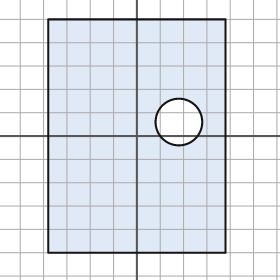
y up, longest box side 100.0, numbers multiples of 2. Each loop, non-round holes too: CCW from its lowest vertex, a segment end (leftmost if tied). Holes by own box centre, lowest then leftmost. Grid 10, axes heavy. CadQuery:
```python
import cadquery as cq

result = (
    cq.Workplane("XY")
    .moveTo(-38.0, -50.0)
    .lineTo(38.0, -50.0)
    .lineTo(38.0, 50.0)
    .lineTo(-38.0, 50.0)
    .close()
    .moveTo(18.0, 6.0)
    .circle(10.0)
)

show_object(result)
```